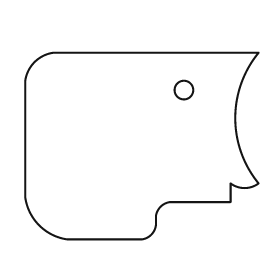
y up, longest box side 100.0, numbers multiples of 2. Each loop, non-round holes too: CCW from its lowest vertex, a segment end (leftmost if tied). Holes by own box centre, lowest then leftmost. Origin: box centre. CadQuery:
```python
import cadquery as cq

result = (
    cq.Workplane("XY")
    .moveTo(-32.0, -40.0)
    .lineTo(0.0, -40.0)
    .threePointArc((4.0, -38.0), (6.0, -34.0))
    .lineTo(6.0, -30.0)
    .threePointArc((8.0, -26.0), (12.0, -24.0))
    .lineTo(38.0, -24.0)
    .lineTo(38.0, -16.0)
    .threePointArc((44.0, -18.0), (50.0, -16.0))
    .threePointArc((40.0, 12.0), (50.0, 40.0))
    .lineTo(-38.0, 40.0)
    .threePointArc((-46.0, 36.0), (-50.0, 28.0))
    .lineTo(-50.0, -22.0)
    .threePointArc((-44.0, -34.0), (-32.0, -40.0))
    .close()
    .moveTo(18.0, 24.0)
    .circle(4.0)
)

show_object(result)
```